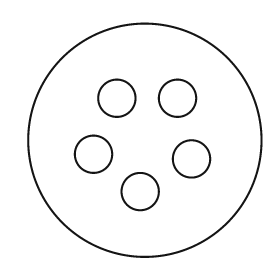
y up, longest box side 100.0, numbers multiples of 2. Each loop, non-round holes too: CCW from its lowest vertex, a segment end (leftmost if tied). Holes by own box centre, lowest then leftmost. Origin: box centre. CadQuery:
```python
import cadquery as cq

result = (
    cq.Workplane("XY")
    .moveTo(0.0, 0.0)
    .circle(50.0)
    .moveTo(-2.0, -22.0)
    .circle(8.0)
    .moveTo(20.0, -8.0)
    .circle(8.0)
    .moveTo(-22.0, -6.0)
    .circle(8.0)
    .moveTo(-12.0, 18.0)
    .circle(8.0)
    .moveTo(14.0, 18.0)
    .circle(8.0)
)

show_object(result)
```